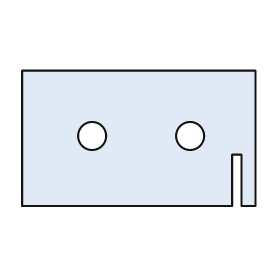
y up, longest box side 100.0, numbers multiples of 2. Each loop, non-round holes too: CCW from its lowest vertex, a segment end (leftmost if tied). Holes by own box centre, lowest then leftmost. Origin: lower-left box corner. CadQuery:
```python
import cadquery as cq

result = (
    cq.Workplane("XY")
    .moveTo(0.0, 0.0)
    .lineTo(90.0, 0.0)
    .lineTo(90.0, 22.0)
    .lineTo(94.0, 22.0)
    .lineTo(94.0, 0.0)
    .lineTo(100.0, 0.0)
    .lineTo(100.0, 58.0)
    .lineTo(0.0, 58.0)
    .close()
    .moveTo(30.0, 30.0)
    .circle(6.0)
    .moveTo(72.0, 30.0)
    .circle(6.0)
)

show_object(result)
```